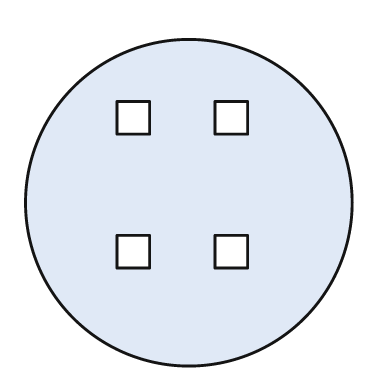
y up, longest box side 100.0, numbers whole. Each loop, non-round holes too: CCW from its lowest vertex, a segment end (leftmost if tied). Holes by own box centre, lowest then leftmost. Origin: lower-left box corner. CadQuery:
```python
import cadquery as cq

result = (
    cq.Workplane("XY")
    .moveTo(50.0, 50.0)
    .circle(50.0)
    .moveTo(28.0, 30.0)
    .lineTo(38.0, 30.0)
    .lineTo(38.0, 40.0)
    .lineTo(28.0, 40.0)
    .close()
    .moveTo(58.0, 30.0)
    .lineTo(68.0, 30.0)
    .lineTo(68.0, 40.0)
    .lineTo(58.0, 40.0)
    .close()
    .moveTo(28.0, 71.0)
    .lineTo(38.0, 71.0)
    .lineTo(38.0, 81.0)
    .lineTo(28.0, 81.0)
    .close()
    .moveTo(58.0, 71.0)
    .lineTo(68.0, 71.0)
    .lineTo(68.0, 81.0)
    .lineTo(58.0, 81.0)
    .close()
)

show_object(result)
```